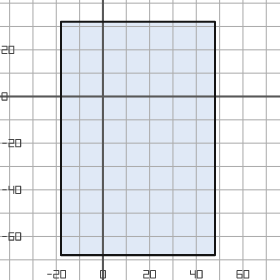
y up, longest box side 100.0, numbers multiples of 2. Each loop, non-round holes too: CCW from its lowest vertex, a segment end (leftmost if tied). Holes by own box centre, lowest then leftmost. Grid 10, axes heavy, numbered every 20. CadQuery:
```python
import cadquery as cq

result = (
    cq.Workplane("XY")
    .moveTo(-18.0, -68.0)
    .lineTo(48.0, -68.0)
    .lineTo(48.0, 32.0)
    .lineTo(-18.0, 32.0)
    .close()
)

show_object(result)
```